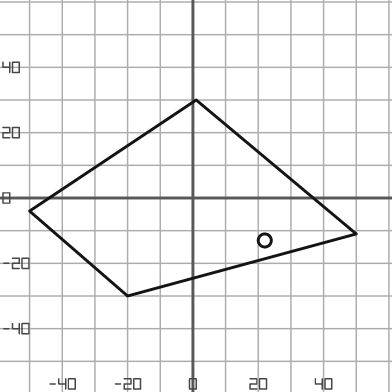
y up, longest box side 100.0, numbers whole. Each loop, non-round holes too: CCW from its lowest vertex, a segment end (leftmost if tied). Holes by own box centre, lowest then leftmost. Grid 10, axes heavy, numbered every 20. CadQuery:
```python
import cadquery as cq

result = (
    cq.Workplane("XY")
    .moveTo(-20.0, -30.0)
    .lineTo(50.0, -11.0)
    .lineTo(1.0, 30.0)
    .lineTo(-50.0, -4.0)
    .close()
    .moveTo(22.0, -13.0)
    .circle(2.0)
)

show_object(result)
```